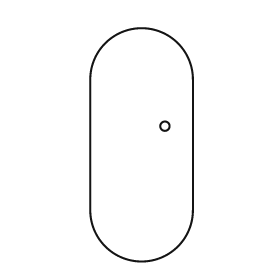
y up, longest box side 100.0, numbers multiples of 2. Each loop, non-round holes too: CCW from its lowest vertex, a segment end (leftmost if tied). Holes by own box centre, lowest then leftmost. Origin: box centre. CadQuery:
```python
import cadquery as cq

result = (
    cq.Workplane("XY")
    .moveTo(-22.0, -28.0)
    .threePointArc((0.0, -50.0), (22.0, -28.0))
    .lineTo(22.0, 28.0)
    .threePointArc((0.0, 50.0), (-22.0, 28.0))
    .close()
    .moveTo(10.0, 8.0)
    .circle(2.0)
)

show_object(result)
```